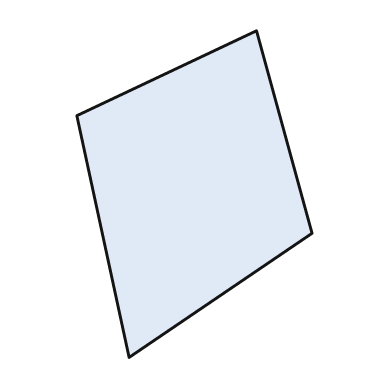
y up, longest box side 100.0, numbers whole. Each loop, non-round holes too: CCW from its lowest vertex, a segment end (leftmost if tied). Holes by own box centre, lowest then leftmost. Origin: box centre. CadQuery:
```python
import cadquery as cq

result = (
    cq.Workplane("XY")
    .moveTo(-20.0, -50.0)
    .lineTo(36.0, -12.0)
    .lineTo(19.0, 50.0)
    .lineTo(-36.0, 24.0)
    .close()
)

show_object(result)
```